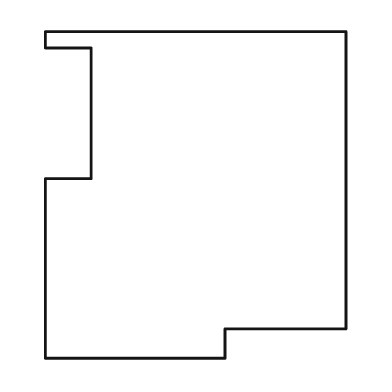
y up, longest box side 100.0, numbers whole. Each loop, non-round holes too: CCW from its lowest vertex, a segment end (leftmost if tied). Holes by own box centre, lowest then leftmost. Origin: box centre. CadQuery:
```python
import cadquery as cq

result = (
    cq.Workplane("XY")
    .moveTo(-46.0, -50.0)
    .lineTo(9.0, -50.0)
    .lineTo(9.0, -41.0)
    .lineTo(46.0, -41.0)
    .lineTo(46.0, 50.0)
    .lineTo(-46.0, 50.0)
    .lineTo(-46.0, 45.0)
    .lineTo(-32.0, 45.0)
    .lineTo(-32.0, 5.0)
    .lineTo(-46.0, 5.0)
    .close()
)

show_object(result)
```